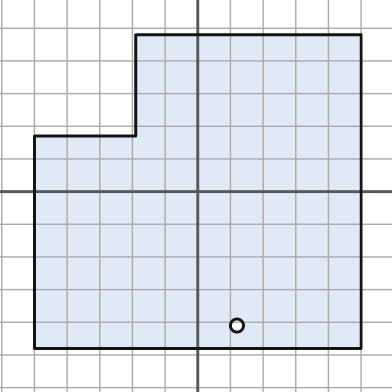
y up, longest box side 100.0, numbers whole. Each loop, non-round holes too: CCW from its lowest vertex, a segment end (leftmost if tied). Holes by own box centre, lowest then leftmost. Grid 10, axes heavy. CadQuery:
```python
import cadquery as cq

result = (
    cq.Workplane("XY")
    .moveTo(-50.0, -48.0)
    .lineTo(50.0, -48.0)
    .lineTo(50.0, 48.0)
    .lineTo(-19.0, 48.0)
    .lineTo(-19.0, 17.0)
    .lineTo(-50.0, 17.0)
    .close()
    .moveTo(12.0, -41.0)
    .circle(2.0)
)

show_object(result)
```